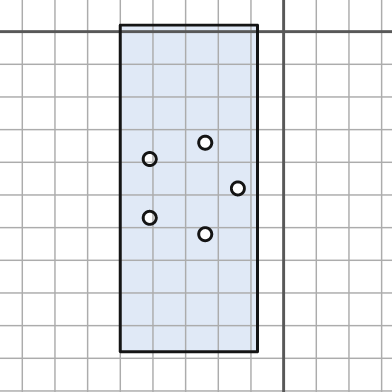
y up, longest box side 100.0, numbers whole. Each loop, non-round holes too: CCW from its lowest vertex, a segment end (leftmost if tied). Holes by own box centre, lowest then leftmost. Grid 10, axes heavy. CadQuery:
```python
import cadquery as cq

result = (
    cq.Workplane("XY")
    .moveTo(-50.0, -98.0)
    .lineTo(-8.0, -98.0)
    .lineTo(-8.0, 2.0)
    .lineTo(-50.0, 2.0)
    .close()
    .moveTo(-24.0, -62.0)
    .circle(2.0)
    .moveTo(-41.0, -57.0)
    .circle(2.0)
    .moveTo(-14.0, -48.0)
    .circle(2.0)
    .moveTo(-41.0, -39.0)
    .circle(2.0)
    .moveTo(-24.0, -34.0)
    .circle(2.0)
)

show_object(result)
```